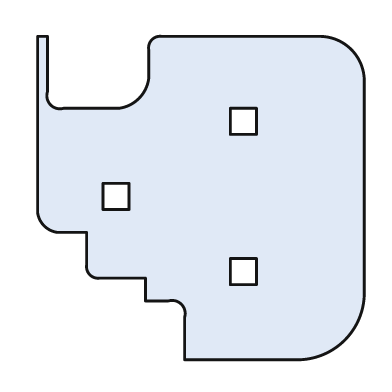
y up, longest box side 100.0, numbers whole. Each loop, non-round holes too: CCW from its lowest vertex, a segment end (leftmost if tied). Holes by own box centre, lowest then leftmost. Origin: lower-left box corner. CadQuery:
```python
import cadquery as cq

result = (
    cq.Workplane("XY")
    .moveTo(45.0, 0.0)
    .lineTo(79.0, 0.0)
    .threePointArc((94.0, 6.0), (100.0, 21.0))
    .lineTo(100.0, 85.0)
    .threePointArc((96.0, 95.0), (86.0, 99.0))
    .lineTo(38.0, 99.0)
    .threePointArc((35.0, 98.0), (34.0, 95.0))
    .lineTo(34.0, 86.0)
    .threePointArc((31.0, 80.0), (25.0, 77.0))
    .lineTo(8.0, 77.0)
    .threePointArc((4.0, 78.0), (3.0, 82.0))
    .lineTo(3.0, 99.0)
    .lineTo(0.0, 99.0)
    .lineTo(0.0, 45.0)
    .threePointArc((2.0, 41.0), (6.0, 39.0))
    .lineTo(15.0, 39.0)
    .lineTo(15.0, 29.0)
    .threePointArc((16.0, 26.0), (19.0, 25.0))
    .lineTo(33.0, 25.0)
    .lineTo(33.0, 18.0)
    .lineTo(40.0, 18.0)
    .threePointArc((44.0, 17.0), (45.0, 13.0))
    .close()
    .moveTo(59.0, 23.0)
    .lineTo(67.0, 23.0)
    .lineTo(67.0, 31.0)
    .lineTo(59.0, 31.0)
    .close()
    .moveTo(20.0, 46.0)
    .lineTo(28.0, 46.0)
    .lineTo(28.0, 54.0)
    .lineTo(20.0, 54.0)
    .close()
    .moveTo(59.0, 69.0)
    .lineTo(67.0, 69.0)
    .lineTo(67.0, 77.0)
    .lineTo(59.0, 77.0)
    .close()
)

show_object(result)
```